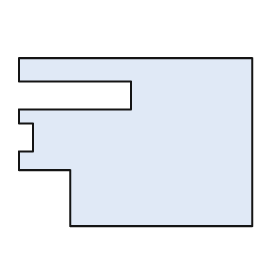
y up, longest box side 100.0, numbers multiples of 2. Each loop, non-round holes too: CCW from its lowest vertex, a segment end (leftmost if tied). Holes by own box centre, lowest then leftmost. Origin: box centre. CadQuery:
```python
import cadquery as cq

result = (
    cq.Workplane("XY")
    .moveTo(-28.0, -36.0)
    .lineTo(50.0, -36.0)
    .lineTo(50.0, 36.0)
    .lineTo(-50.0, 36.0)
    .lineTo(-50.0, 26.0)
    .lineTo(-2.0, 26.0)
    .lineTo(-2.0, 14.0)
    .lineTo(-50.0, 14.0)
    .lineTo(-50.0, 8.0)
    .lineTo(-44.0, 8.0)
    .lineTo(-44.0, -4.0)
    .lineTo(-50.0, -4.0)
    .lineTo(-50.0, -12.0)
    .lineTo(-28.0, -12.0)
    .close()
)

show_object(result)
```